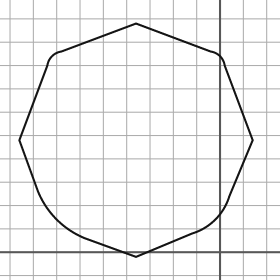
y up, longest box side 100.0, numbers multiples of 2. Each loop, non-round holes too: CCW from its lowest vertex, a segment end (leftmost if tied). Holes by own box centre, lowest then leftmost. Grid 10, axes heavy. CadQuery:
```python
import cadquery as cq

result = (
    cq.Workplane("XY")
    .moveTo(-36.0, -2.0)
    .lineTo(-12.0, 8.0)
    .threePointArc((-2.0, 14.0), (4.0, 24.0))
    .lineTo(14.0, 48.0)
    .lineTo(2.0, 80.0)
    .threePointArc((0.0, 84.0), (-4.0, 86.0))
    .lineTo(-36.0, 98.0)
    .lineTo(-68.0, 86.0)
    .threePointArc((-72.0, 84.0), (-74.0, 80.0))
    .lineTo(-86.0, 48.0)
    .lineTo(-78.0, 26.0)
    .threePointArc((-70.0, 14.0), (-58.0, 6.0))
    .close()
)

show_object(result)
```